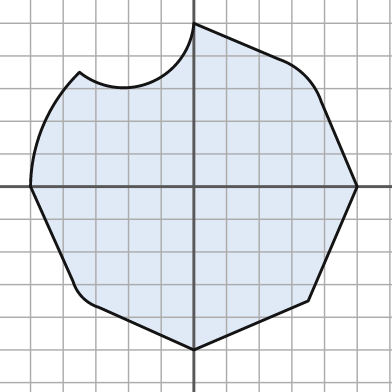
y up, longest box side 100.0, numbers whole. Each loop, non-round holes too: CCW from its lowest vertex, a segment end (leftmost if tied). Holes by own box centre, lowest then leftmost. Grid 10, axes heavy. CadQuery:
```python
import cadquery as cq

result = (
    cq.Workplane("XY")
    .moveTo(0.0, -50.0)
    .lineTo(35.0, -35.0)
    .lineTo(50.0, 0.0)
    .lineTo(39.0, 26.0)
    .threePointArc((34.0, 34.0), (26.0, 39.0))
    .lineTo(0.0, 50.0)
    .threePointArc((-13.0, 32.0), (-35.0, 35.0))
    .threePointArc((-46.0, 19.0), (-50.0, 0.0))
    .lineTo(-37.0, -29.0)
    .threePointArc((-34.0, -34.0), (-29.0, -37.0))
    .close()
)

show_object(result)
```